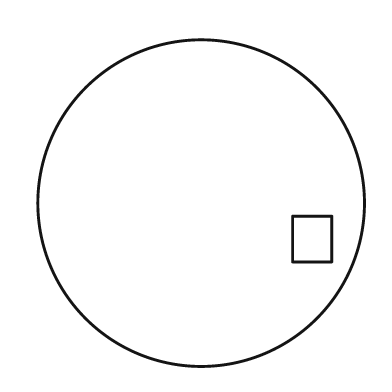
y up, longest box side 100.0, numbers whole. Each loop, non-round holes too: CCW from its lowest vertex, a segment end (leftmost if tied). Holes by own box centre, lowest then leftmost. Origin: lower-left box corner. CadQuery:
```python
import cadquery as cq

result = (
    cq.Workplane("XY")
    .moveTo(50.0, 50.0)
    .circle(50.0)
    .moveTo(78.0, 32.0)
    .lineTo(90.0, 32.0)
    .lineTo(90.0, 46.0)
    .lineTo(78.0, 46.0)
    .close()
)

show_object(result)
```